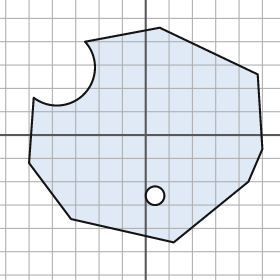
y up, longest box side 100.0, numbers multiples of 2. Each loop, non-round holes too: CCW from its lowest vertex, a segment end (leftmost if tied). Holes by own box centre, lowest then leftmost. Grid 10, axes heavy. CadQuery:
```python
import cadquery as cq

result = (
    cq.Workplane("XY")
    .moveTo(12.0, -46.0)
    .lineTo(44.0, -20.0)
    .lineTo(50.0, -6.0)
    .lineTo(48.0, 26.0)
    .lineTo(6.0, 46.0)
    .lineTo(-26.0, 40.0)
    .threePointArc((-26.0, 18.0), (-48.0, 16.0))
    .lineTo(-50.0, -12.0)
    .lineTo(-32.0, -36.0)
    .close()
    .moveTo(4.0, -26.0)
    .circle(4.0)
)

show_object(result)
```